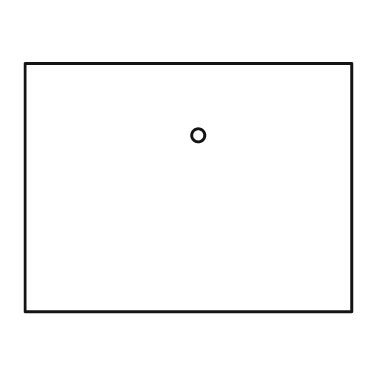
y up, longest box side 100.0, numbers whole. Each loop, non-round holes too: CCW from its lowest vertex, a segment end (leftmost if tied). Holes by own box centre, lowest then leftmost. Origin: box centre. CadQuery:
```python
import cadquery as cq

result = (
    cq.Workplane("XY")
    .moveTo(-50.0, -38.0)
    .lineTo(50.0, -38.0)
    .lineTo(50.0, 38.0)
    .lineTo(-50.0, 38.0)
    .close()
    .moveTo(3.0, 16.0)
    .circle(2.0)
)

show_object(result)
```